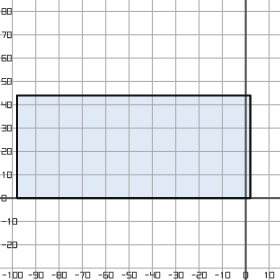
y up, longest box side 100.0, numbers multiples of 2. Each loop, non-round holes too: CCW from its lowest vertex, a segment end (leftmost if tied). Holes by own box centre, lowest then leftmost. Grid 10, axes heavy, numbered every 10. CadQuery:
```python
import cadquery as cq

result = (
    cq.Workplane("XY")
    .moveTo(-98.0, 0.0)
    .lineTo(2.0, 0.0)
    .lineTo(2.0, 44.0)
    .lineTo(-98.0, 44.0)
    .close()
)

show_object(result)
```